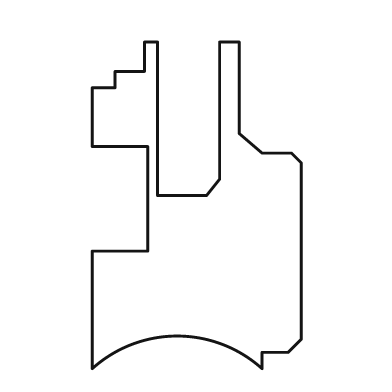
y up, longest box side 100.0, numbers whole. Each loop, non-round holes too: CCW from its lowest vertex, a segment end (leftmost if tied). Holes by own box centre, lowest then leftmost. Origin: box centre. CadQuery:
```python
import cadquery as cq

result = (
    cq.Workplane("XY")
    .moveTo(-32.0, -50.0)
    .threePointArc((-6.0, -40.0), (20.0, -50.0))
    .lineTo(20.0, -45.0)
    .lineTo(28.0, -45.0)
    .lineTo(32.0, -41.0)
    .lineTo(32.0, 13.0)
    .lineTo(29.0, 16.0)
    .lineTo(20.0, 16.0)
    .lineTo(13.0, 22.0)
    .lineTo(13.0, 50.0)
    .lineTo(7.0, 50.0)
    .lineTo(7.0, 8.0)
    .lineTo(3.0, 3.0)
    .lineTo(-12.0, 3.0)
    .lineTo(-12.0, 50.0)
    .lineTo(-16.0, 50.0)
    .lineTo(-16.0, 41.0)
    .lineTo(-25.0, 41.0)
    .lineTo(-25.0, 36.0)
    .lineTo(-32.0, 36.0)
    .lineTo(-32.0, 18.0)
    .lineTo(-15.0, 18.0)
    .lineTo(-15.0, -14.0)
    .lineTo(-32.0, -14.0)
    .close()
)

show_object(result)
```